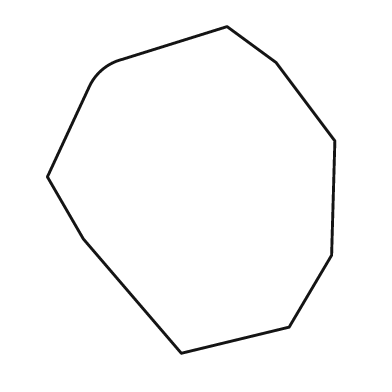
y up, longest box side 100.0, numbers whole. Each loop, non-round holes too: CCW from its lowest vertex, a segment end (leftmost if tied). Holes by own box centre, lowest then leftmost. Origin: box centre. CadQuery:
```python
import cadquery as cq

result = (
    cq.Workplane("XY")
    .moveTo(-3.0, -50.0)
    .lineTo(30.0, -42.0)
    .lineTo(43.0, -20.0)
    .lineTo(44.0, 15.0)
    .lineTo(26.0, 39.0)
    .lineTo(11.0, 50.0)
    .lineTo(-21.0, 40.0)
    .threePointArc((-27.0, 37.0), (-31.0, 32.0))
    .lineTo(-44.0, 4.0)
    .lineTo(-33.0, -15.0)
    .close()
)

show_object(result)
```